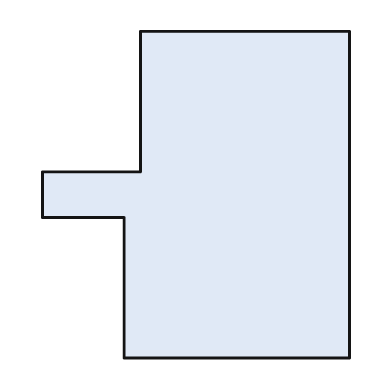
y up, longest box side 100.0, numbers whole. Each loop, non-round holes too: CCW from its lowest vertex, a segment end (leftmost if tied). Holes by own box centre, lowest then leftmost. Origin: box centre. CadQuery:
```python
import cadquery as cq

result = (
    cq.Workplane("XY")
    .moveTo(-22.0, -50.0)
    .lineTo(47.0, -50.0)
    .lineTo(47.0, 50.0)
    .lineTo(-17.0, 50.0)
    .lineTo(-17.0, 7.0)
    .lineTo(-47.0, 7.0)
    .lineTo(-47.0, -7.0)
    .lineTo(-22.0, -7.0)
    .close()
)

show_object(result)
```